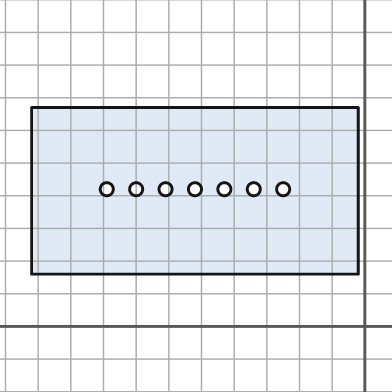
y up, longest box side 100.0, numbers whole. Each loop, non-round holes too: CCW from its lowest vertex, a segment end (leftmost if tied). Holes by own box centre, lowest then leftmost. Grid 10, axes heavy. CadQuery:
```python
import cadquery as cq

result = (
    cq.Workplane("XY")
    .moveTo(-102.0, 16.0)
    .lineTo(-2.0, 16.0)
    .lineTo(-2.0, 67.0)
    .lineTo(-102.0, 67.0)
    .close()
    .moveTo(-79.0, 42.0)
    .circle(2.0)
    .moveTo(-70.0, 42.0)
    .circle(2.0)
    .moveTo(-61.0, 42.0)
    .circle(2.0)
    .moveTo(-52.0, 42.0)
    .circle(2.0)
    .moveTo(-43.0, 42.0)
    .circle(2.0)
    .moveTo(-34.0, 42.0)
    .circle(2.0)
    .moveTo(-25.0, 42.0)
    .circle(2.0)
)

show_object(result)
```